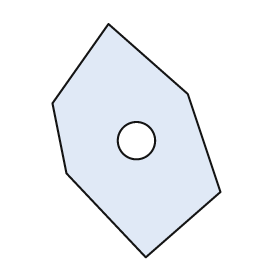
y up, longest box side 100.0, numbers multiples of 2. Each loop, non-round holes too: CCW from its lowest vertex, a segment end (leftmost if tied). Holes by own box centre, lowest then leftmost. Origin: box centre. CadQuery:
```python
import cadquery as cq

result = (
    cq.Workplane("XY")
    .moveTo(4.0, -50.0)
    .lineTo(36.0, -22.0)
    .lineTo(22.0, 20.0)
    .lineTo(-12.0, 50.0)
    .lineTo(-36.0, 16.0)
    .lineTo(-30.0, -14.0)
    .close()
    .moveTo(0.0, 0.0)
    .circle(8.0)
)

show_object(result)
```